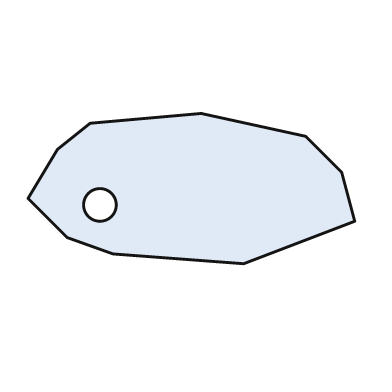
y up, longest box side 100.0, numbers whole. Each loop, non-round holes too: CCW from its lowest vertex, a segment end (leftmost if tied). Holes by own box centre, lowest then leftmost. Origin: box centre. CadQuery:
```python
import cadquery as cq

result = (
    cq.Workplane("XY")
    .moveTo(16.0, -23.0)
    .lineTo(50.0, -10.0)
    .lineTo(46.0, 5.0)
    .lineTo(35.0, 16.0)
    .lineTo(3.0, 23.0)
    .lineTo(-31.0, 20.0)
    .lineTo(-41.0, 12.0)
    .lineTo(-50.0, -3.0)
    .lineTo(-38.0, -15.0)
    .lineTo(-24.0, -20.0)
    .close()
    .moveTo(-28.0, -5.0)
    .circle(5.0)
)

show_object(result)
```